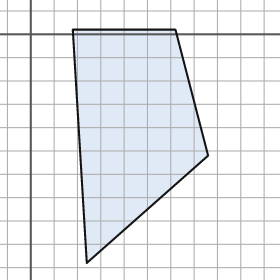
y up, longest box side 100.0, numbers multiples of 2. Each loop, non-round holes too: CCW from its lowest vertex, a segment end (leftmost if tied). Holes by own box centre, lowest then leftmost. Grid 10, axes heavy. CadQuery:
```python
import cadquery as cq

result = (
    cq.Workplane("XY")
    .moveTo(24.0, -98.0)
    .lineTo(76.0, -52.0)
    .lineTo(62.0, 2.0)
    .lineTo(18.0, 2.0)
    .close()
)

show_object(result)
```